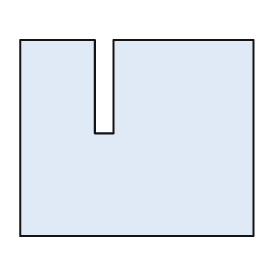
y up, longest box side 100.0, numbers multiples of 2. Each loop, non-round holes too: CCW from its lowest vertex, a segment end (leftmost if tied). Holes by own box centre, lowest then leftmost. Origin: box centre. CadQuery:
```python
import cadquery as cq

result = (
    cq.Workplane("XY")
    .moveTo(-50.0, -42.0)
    .lineTo(50.0, -42.0)
    .lineTo(50.0, 42.0)
    .lineTo(-10.0, 42.0)
    .lineTo(-10.0, 2.0)
    .lineTo(-18.0, 2.0)
    .lineTo(-18.0, 42.0)
    .lineTo(-50.0, 42.0)
    .close()
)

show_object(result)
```